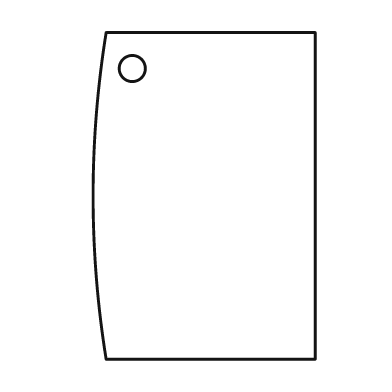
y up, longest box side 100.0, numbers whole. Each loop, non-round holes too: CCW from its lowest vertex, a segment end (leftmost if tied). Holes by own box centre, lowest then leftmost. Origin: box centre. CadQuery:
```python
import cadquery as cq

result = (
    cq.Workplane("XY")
    .moveTo(-30.0, -50.0)
    .lineTo(34.0, -50.0)
    .lineTo(34.0, 50.0)
    .lineTo(-30.0, 50.0)
    .threePointArc((-34.0, 0.0), (-30.0, -50.0))
    .close()
    .moveTo(-22.0, 39.0)
    .circle(4.0)
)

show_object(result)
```